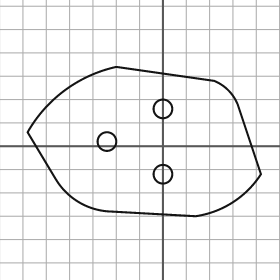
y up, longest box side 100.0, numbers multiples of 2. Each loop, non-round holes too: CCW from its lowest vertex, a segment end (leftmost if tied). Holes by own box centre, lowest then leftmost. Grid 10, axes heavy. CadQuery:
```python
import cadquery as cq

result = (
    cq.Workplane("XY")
    .moveTo(14.0, -30.0)
    .threePointArc((30.0, -24.0), (42.0, -12.0))
    .lineTo(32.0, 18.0)
    .threePointArc((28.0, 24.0), (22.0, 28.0))
    .lineTo(-20.0, 34.0)
    .threePointArc((-42.0, 24.0), (-58.0, 6.0))
    .lineTo(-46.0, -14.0)
    .threePointArc((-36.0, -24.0), (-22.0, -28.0))
    .close()
    .moveTo(0.0, -12.0)
    .circle(4.0)
    .moveTo(-24.0, 2.0)
    .circle(4.0)
    .moveTo(0.0, 16.0)
    .circle(4.0)
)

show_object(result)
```